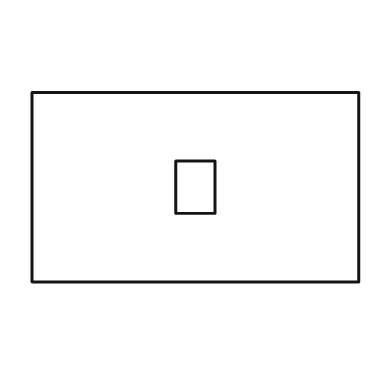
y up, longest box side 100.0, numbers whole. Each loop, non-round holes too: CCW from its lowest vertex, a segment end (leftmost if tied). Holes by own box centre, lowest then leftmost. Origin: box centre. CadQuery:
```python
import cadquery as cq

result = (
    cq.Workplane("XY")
    .moveTo(-50.0, -29.0)
    .lineTo(50.0, -29.0)
    .lineTo(50.0, 29.0)
    .lineTo(-50.0, 29.0)
    .close()
    .moveTo(-6.0, -8.0)
    .lineTo(6.0, -8.0)
    .lineTo(6.0, 8.0)
    .lineTo(-6.0, 8.0)
    .close()
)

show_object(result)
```